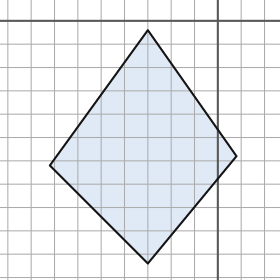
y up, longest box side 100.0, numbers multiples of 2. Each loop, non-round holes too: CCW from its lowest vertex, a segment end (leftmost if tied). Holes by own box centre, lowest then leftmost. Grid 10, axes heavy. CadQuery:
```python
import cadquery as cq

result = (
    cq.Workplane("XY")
    .moveTo(-30.0, -104.0)
    .lineTo(8.0, -58.0)
    .lineTo(-30.0, -4.0)
    .lineTo(-72.0, -62.0)
    .close()
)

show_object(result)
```